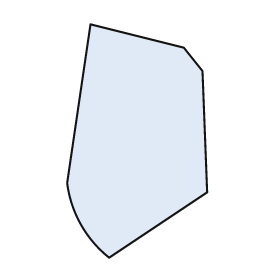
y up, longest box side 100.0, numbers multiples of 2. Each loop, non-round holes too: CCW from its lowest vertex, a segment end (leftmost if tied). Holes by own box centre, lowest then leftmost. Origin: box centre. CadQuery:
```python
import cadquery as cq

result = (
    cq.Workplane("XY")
    .moveTo(-12.0, -50.0)
    .lineTo(30.0, -22.0)
    .lineTo(28.0, 30.0)
    .lineTo(20.0, 40.0)
    .lineTo(-20.0, 50.0)
    .lineTo(-30.0, -18.0)
    .threePointArc((-24.0, -36.0), (-12.0, -50.0))
    .close()
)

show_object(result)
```